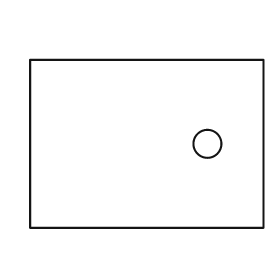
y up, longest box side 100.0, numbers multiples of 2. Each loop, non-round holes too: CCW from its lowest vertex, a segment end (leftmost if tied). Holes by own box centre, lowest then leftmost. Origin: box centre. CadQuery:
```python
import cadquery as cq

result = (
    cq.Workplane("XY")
    .moveTo(-50.0, -36.0)
    .lineTo(50.0, -36.0)
    .lineTo(50.0, 36.0)
    .lineTo(-50.0, 36.0)
    .close()
    .moveTo(26.0, 0.0)
    .circle(6.0)
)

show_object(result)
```